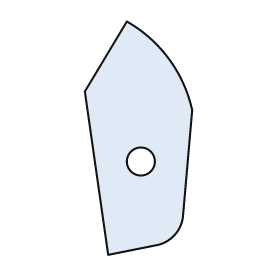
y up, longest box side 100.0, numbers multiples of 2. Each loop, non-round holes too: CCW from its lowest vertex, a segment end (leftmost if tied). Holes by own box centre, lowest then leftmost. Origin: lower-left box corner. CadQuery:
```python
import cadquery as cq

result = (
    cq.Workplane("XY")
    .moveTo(10.0, 0.0)
    .lineTo(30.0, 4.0)
    .threePointArc((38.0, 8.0), (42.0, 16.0))
    .lineTo(46.0, 62.0)
    .threePointArc((36.0, 84.0), (18.0, 100.0))
    .lineTo(0.0, 70.0)
    .close()
    .moveTo(24.0, 40.0)
    .circle(6.0)
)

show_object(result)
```